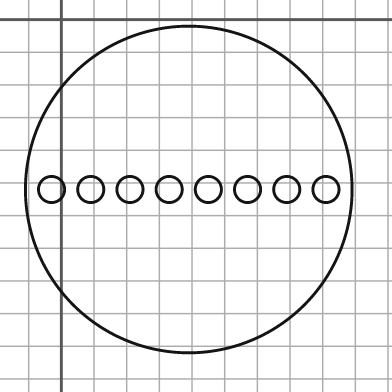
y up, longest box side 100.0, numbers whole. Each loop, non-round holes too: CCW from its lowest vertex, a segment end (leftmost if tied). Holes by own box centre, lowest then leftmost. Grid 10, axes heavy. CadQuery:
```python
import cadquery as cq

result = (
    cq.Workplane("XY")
    .moveTo(39.0, -52.0)
    .circle(50.0)
    .moveTo(-3.0, -52.0)
    .circle(4.0)
    .moveTo(9.0, -52.0)
    .circle(4.0)
    .moveTo(21.0, -52.0)
    .circle(4.0)
    .moveTo(33.0, -52.0)
    .circle(4.0)
    .moveTo(45.0, -52.0)
    .circle(4.0)
    .moveTo(57.0, -52.0)
    .circle(4.0)
    .moveTo(69.0, -52.0)
    .circle(4.0)
    .moveTo(81.0, -52.0)
    .circle(4.0)
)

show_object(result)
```